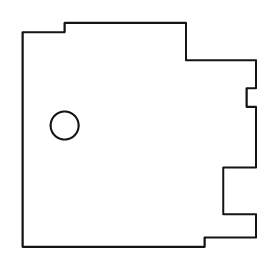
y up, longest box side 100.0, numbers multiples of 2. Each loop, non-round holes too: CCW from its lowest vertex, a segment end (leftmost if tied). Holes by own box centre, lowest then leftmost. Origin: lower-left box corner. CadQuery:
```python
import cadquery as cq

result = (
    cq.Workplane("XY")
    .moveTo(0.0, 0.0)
    .lineTo(78.0, 0.0)
    .lineTo(78.0, 4.0)
    .lineTo(100.0, 4.0)
    .lineTo(100.0, 14.0)
    .lineTo(86.0, 14.0)
    .lineTo(86.0, 34.0)
    .lineTo(100.0, 34.0)
    .lineTo(100.0, 60.0)
    .lineTo(96.0, 60.0)
    .lineTo(96.0, 68.0)
    .lineTo(100.0, 68.0)
    .lineTo(100.0, 80.0)
    .lineTo(70.0, 80.0)
    .lineTo(70.0, 96.0)
    .lineTo(18.0, 96.0)
    .lineTo(18.0, 92.0)
    .lineTo(0.0, 92.0)
    .close()
    .moveTo(18.0, 52.0)
    .circle(6.0)
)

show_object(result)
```